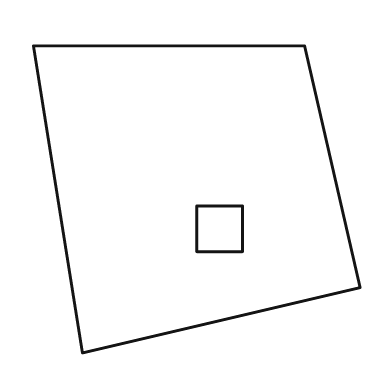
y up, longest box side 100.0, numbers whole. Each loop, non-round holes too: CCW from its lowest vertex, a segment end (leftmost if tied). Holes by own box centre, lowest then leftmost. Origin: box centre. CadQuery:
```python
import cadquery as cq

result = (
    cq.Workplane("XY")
    .moveTo(-35.0, -47.0)
    .lineTo(50.0, -27.0)
    .lineTo(33.0, 47.0)
    .lineTo(-50.0, 47.0)
    .close()
    .moveTo(0.0, -16.0)
    .lineTo(14.0, -16.0)
    .lineTo(14.0, -2.0)
    .lineTo(0.0, -2.0)
    .close()
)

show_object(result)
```